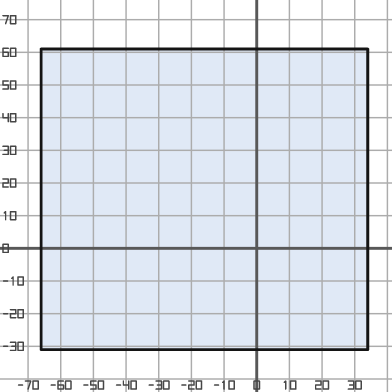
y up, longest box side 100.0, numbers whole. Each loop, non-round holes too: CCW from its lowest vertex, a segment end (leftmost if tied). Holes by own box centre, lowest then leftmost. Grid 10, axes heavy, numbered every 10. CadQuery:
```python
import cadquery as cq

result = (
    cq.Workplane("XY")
    .moveTo(-66.0, -31.0)
    .lineTo(34.0, -31.0)
    .lineTo(34.0, 61.0)
    .lineTo(-66.0, 61.0)
    .close()
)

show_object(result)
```